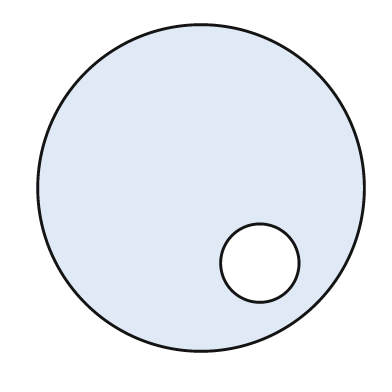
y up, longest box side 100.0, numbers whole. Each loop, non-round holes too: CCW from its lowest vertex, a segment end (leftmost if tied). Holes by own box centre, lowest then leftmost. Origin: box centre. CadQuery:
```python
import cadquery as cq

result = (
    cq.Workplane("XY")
    .moveTo(0.0, 0.0)
    .circle(50.0)
    .moveTo(18.0, -23.0)
    .circle(12.0)
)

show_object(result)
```